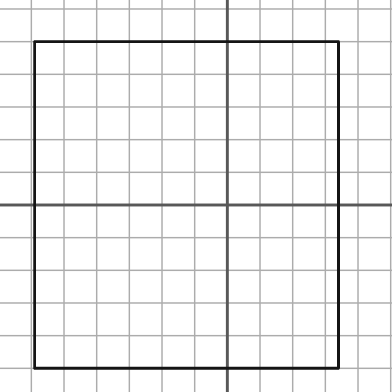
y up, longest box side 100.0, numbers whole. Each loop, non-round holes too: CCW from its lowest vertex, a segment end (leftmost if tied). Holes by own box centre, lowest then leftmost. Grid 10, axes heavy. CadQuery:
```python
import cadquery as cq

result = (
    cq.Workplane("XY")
    .moveTo(-59.0, -50.0)
    .lineTo(34.0, -50.0)
    .lineTo(34.0, 50.0)
    .lineTo(-59.0, 50.0)
    .close()
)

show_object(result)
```